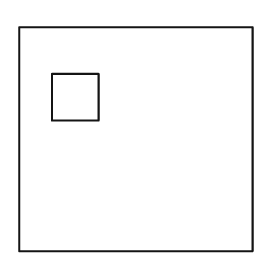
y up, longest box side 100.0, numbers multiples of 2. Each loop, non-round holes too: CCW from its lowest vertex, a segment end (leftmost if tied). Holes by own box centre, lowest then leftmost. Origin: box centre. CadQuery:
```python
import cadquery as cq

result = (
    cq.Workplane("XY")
    .moveTo(-50.0, -48.0)
    .lineTo(50.0, -48.0)
    .lineTo(50.0, 48.0)
    .lineTo(-50.0, 48.0)
    .close()
    .moveTo(-36.0, 8.0)
    .lineTo(-16.0, 8.0)
    .lineTo(-16.0, 28.0)
    .lineTo(-36.0, 28.0)
    .close()
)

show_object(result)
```